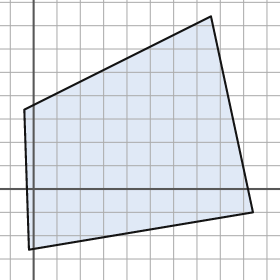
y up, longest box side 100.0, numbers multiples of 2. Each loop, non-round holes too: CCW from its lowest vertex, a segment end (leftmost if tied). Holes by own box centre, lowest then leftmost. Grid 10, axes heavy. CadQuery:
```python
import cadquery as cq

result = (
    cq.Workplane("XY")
    .moveTo(-2.0, -26.0)
    .lineTo(94.0, -10.0)
    .lineTo(76.0, 74.0)
    .lineTo(-4.0, 34.0)
    .close()
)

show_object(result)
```